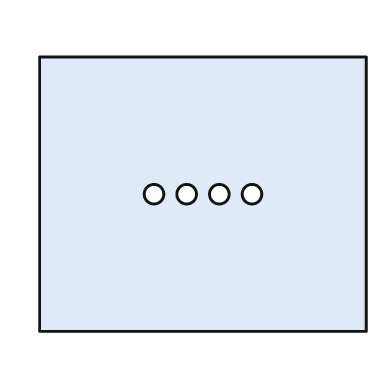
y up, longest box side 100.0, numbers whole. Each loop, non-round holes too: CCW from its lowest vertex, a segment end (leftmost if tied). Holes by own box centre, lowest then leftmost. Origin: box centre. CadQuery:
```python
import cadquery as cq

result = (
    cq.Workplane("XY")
    .moveTo(-50.0, -42.0)
    .lineTo(50.0, -42.0)
    .lineTo(50.0, 42.0)
    .lineTo(-50.0, 42.0)
    .close()
    .moveTo(-15.0, 0.0)
    .circle(3.0)
    .moveTo(-5.0, 0.0)
    .circle(3.0)
    .moveTo(5.0, 0.0)
    .circle(3.0)
    .moveTo(15.0, 0.0)
    .circle(3.0)
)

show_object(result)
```